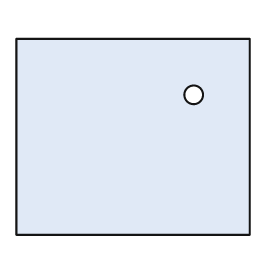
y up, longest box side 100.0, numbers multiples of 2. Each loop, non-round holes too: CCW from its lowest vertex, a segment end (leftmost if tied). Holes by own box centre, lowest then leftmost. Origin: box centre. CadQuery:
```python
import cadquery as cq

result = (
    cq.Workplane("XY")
    .moveTo(-50.0, -42.0)
    .lineTo(50.0, -42.0)
    .lineTo(50.0, 42.0)
    .lineTo(-50.0, 42.0)
    .close()
    .moveTo(26.0, 18.0)
    .circle(4.0)
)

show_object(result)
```